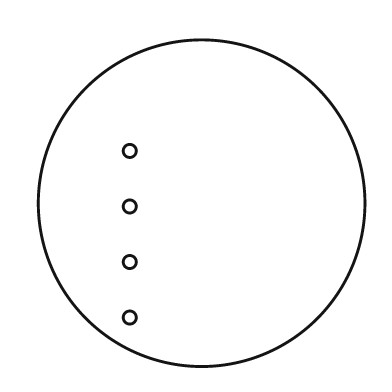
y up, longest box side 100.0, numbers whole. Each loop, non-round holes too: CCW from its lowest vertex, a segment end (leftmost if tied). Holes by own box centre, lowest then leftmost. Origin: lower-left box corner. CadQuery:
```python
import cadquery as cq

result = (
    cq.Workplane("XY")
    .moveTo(50.0, 50.0)
    .circle(50.0)
    .moveTo(28.0, 15.0)
    .circle(2.0)
    .moveTo(28.0, 32.0)
    .circle(2.0)
    .moveTo(28.0, 49.0)
    .circle(2.0)
    .moveTo(28.0, 66.0)
    .circle(2.0)
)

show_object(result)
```